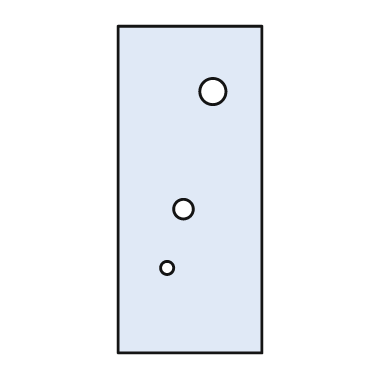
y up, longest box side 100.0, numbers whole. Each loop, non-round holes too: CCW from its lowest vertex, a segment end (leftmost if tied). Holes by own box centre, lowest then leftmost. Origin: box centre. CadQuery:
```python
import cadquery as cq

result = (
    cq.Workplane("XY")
    .moveTo(-22.0, -50.0)
    .lineTo(22.0, -50.0)
    .lineTo(22.0, 50.0)
    .lineTo(-22.0, 50.0)
    .close()
    .moveTo(-7.0, -24.0)
    .circle(2.0)
    .moveTo(-2.0, -6.0)
    .circle(3.0)
    .moveTo(7.0, 30.0)
    .circle(4.0)
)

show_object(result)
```